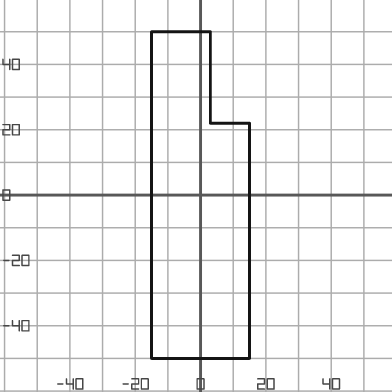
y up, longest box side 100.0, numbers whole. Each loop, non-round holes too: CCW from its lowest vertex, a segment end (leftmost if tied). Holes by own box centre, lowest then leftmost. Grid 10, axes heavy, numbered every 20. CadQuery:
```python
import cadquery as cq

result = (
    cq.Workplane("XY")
    .moveTo(-15.0, -50.0)
    .lineTo(15.0, -50.0)
    .lineTo(15.0, 22.0)
    .lineTo(3.0, 22.0)
    .lineTo(3.0, 50.0)
    .lineTo(-15.0, 50.0)
    .close()
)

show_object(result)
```